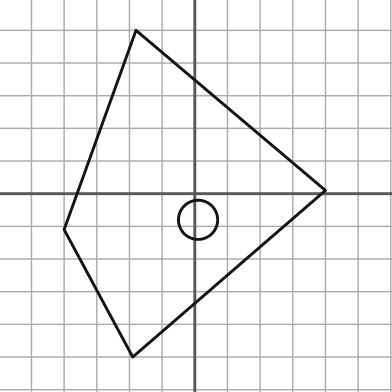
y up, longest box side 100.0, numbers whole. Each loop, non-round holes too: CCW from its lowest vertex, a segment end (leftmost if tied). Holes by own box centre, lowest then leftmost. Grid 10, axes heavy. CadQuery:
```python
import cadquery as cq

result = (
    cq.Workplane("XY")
    .moveTo(-19.0, -50.0)
    .lineTo(40.0, 1.0)
    .lineTo(-18.0, 50.0)
    .lineTo(-40.0, -11.0)
    .close()
    .moveTo(1.0, -8.0)
    .circle(6.0)
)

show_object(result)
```